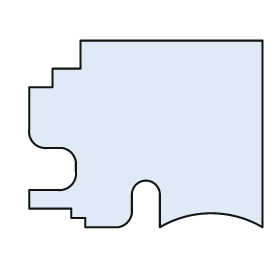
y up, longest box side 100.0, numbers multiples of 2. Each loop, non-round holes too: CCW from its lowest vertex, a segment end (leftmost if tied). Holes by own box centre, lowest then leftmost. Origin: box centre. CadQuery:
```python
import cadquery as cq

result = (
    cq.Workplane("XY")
    .moveTo(-26.0, -40.0)
    .lineTo(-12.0, -40.0)
    .threePointArc((-8.0, -38.0), (-6.0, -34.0))
    .lineTo(-6.0, -26.0)
    .threePointArc((0.0, -20.0), (6.0, -26.0))
    .lineTo(6.0, -40.0)
    .threePointArc((28.0, -34.0), (50.0, -40.0))
    .lineTo(50.0, 40.0)
    .lineTo(-28.0, 40.0)
    .lineTo(-28.0, 28.0)
    .lineTo(-40.0, 28.0)
    .lineTo(-40.0, 20.0)
    .lineTo(-50.0, 20.0)
    .lineTo(-50.0, 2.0)
    .threePointArc((-48.0, -4.0), (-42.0, -6.0))
    .lineTo(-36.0, -6.0)
    .threePointArc((-32.0, -8.0), (-30.0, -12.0))
    .lineTo(-30.0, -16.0)
    .threePointArc((-32.0, -22.0), (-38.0, -24.0))
    .lineTo(-50.0, -24.0)
    .lineTo(-50.0, -32.0)
    .lineTo(-32.0, -32.0)
    .lineTo(-32.0, -36.0)
    .lineTo(-26.0, -36.0)
    .close()
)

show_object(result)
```